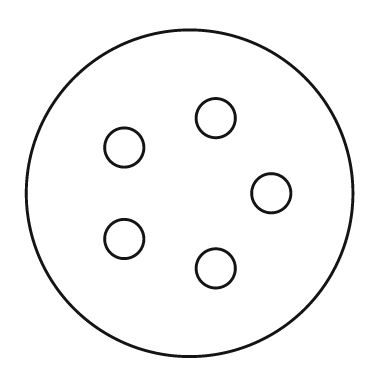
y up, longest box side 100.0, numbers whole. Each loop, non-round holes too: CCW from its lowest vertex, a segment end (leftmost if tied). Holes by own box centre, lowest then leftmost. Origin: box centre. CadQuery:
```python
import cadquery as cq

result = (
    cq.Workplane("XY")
    .moveTo(0.0, 0.0)
    .circle(50.0)
    .moveTo(8.0, -23.0)
    .circle(6.0)
    .moveTo(-20.0, -14.0)
    .circle(6.0)
    .moveTo(25.0, 0.0)
    .circle(6.0)
    .moveTo(-20.0, 14.0)
    .circle(6.0)
    .moveTo(8.0, 23.0)
    .circle(6.0)
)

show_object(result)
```